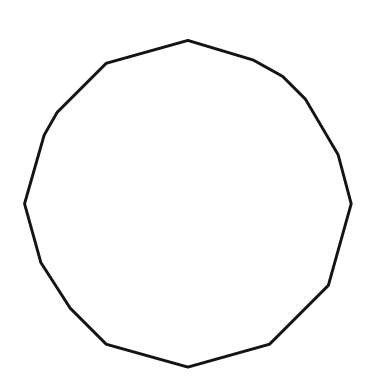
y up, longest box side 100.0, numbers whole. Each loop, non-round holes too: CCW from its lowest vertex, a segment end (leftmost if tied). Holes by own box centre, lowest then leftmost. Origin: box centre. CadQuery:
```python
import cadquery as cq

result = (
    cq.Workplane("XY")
    .moveTo(0.0, -50.0)
    .lineTo(25.0, -43.0)
    .lineTo(43.0, -25.0)
    .lineTo(50.0, 0.0)
    .lineTo(46.0, 15.0)
    .lineTo(36.0, 32.0)
    .lineTo(29.0, 39.0)
    .lineTo(20.0, 44.0)
    .lineTo(0.0, 50.0)
    .lineTo(-25.0, 43.0)
    .lineTo(-40.0, 28.0)
    .lineTo(-44.0, 21.0)
    .lineTo(-50.0, 0.0)
    .lineTo(-45.0, -18.0)
    .lineTo(-36.0, -32.0)
    .lineTo(-25.0, -43.0)
    .close()
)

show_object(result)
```